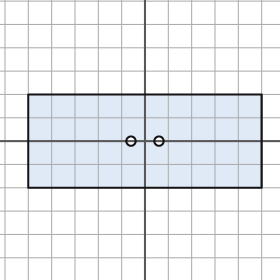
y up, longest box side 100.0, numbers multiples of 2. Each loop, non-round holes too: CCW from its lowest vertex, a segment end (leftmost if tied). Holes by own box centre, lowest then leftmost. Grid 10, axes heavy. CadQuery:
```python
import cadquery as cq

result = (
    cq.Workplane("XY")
    .moveTo(-50.0, -20.0)
    .lineTo(50.0, -20.0)
    .lineTo(50.0, 20.0)
    .lineTo(-50.0, 20.0)
    .close()
    .moveTo(-6.0, 0.0)
    .circle(2.0)
    .moveTo(6.0, 0.0)
    .circle(2.0)
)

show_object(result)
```